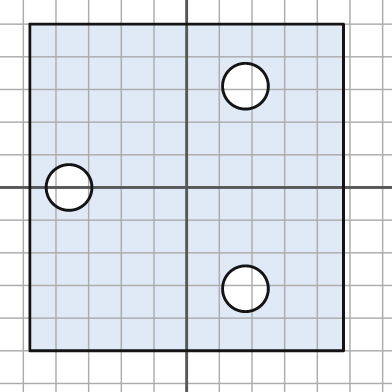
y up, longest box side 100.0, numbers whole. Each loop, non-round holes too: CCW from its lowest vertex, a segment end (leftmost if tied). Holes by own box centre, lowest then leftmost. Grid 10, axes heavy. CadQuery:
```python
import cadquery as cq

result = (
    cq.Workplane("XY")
    .moveTo(-48.0, -50.0)
    .lineTo(48.0, -50.0)
    .lineTo(48.0, 50.0)
    .lineTo(-48.0, 50.0)
    .close()
    .moveTo(18.0, -31.0)
    .circle(7.0)
    .moveTo(-36.0, 0.0)
    .circle(7.0)
    .moveTo(18.0, 31.0)
    .circle(7.0)
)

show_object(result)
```